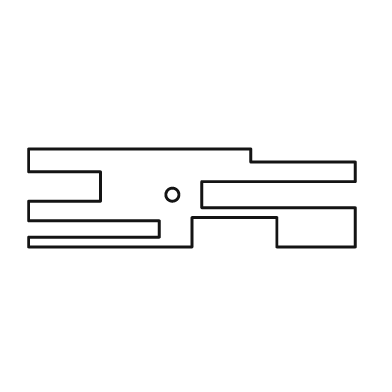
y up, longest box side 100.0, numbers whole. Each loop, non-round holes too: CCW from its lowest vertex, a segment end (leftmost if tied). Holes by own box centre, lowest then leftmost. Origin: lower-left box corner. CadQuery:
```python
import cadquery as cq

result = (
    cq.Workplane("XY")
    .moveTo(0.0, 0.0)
    .lineTo(50.0, 0.0)
    .lineTo(50.0, 9.0)
    .lineTo(76.0, 9.0)
    .lineTo(76.0, 0.0)
    .lineTo(100.0, 0.0)
    .lineTo(100.0, 12.0)
    .lineTo(53.0, 12.0)
    .lineTo(53.0, 20.0)
    .lineTo(100.0, 20.0)
    .lineTo(100.0, 26.0)
    .lineTo(68.0, 26.0)
    .lineTo(68.0, 30.0)
    .lineTo(0.0, 30.0)
    .lineTo(0.0, 23.0)
    .lineTo(22.0, 23.0)
    .lineTo(22.0, 14.0)
    .lineTo(0.0, 14.0)
    .lineTo(0.0, 8.0)
    .lineTo(40.0, 8.0)
    .lineTo(40.0, 3.0)
    .lineTo(0.0, 3.0)
    .close()
    .moveTo(44.0, 16.0)
    .circle(2.0)
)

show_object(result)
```